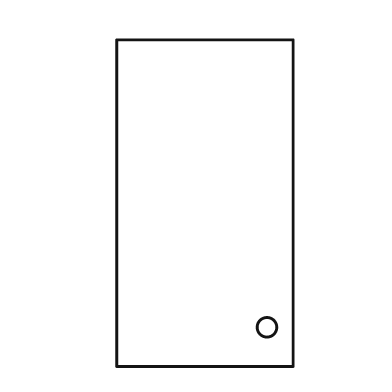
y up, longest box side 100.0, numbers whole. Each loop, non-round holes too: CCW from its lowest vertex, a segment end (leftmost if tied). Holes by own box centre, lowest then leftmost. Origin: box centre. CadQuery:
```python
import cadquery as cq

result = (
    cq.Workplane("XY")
    .moveTo(-27.0, -50.0)
    .lineTo(27.0, -50.0)
    .lineTo(27.0, 50.0)
    .lineTo(-27.0, 50.0)
    .close()
    .moveTo(19.0, -38.0)
    .circle(3.0)
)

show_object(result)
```